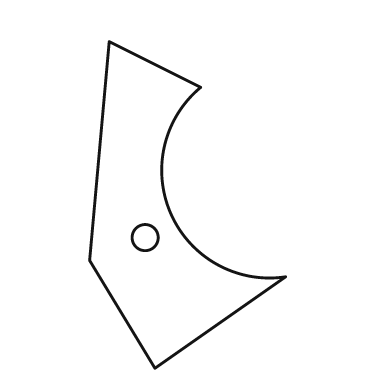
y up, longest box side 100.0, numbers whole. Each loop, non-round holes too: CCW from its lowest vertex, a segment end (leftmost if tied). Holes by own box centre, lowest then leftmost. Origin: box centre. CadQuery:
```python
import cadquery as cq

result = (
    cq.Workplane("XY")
    .moveTo(-10.0, -50.0)
    .lineTo(30.0, -22.0)
    .threePointArc((-5.0, -3.0), (4.0, 36.0))
    .lineTo(-24.0, 50.0)
    .lineTo(-30.0, -17.0)
    .close()
    .moveTo(-13.0, -10.0)
    .circle(4.0)
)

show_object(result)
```